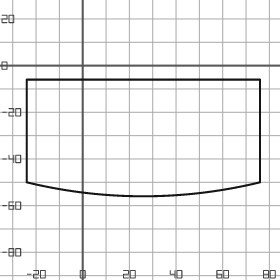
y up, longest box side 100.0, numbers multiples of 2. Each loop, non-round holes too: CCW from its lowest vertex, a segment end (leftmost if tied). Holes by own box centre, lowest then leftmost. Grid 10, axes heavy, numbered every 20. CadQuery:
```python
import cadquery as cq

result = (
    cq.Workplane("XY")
    .moveTo(-24.0, -50.0)
    .threePointArc((26.0, -56.0), (76.0, -50.0))
    .lineTo(76.0, -6.0)
    .lineTo(-24.0, -6.0)
    .close()
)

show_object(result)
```